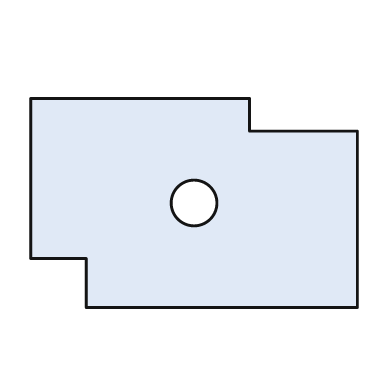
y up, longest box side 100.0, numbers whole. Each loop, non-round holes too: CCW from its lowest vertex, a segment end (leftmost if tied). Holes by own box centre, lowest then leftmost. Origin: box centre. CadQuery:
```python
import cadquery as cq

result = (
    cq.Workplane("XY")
    .moveTo(-33.0, -32.0)
    .lineTo(50.0, -32.0)
    .lineTo(50.0, 22.0)
    .lineTo(17.0, 22.0)
    .lineTo(17.0, 32.0)
    .lineTo(-50.0, 32.0)
    .lineTo(-50.0, -17.0)
    .lineTo(-33.0, -17.0)
    .close()
    .moveTo(0.0, 0.0)
    .circle(7.0)
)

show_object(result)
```